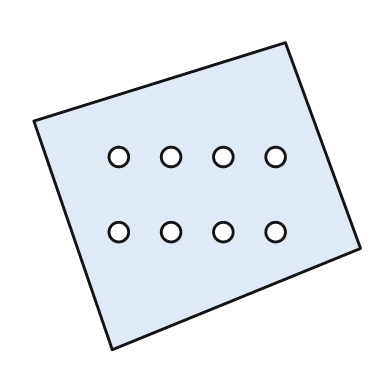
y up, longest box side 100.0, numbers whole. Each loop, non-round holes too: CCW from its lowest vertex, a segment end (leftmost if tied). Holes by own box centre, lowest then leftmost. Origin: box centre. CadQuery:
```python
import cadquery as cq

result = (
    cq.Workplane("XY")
    .moveTo(-26.0, -47.0)
    .lineTo(50.0, -16.0)
    .lineTo(27.0, 47.0)
    .lineTo(-50.0, 23.0)
    .close()
    .moveTo(-24.0, -11.0)
    .circle(3.0)
    .moveTo(-8.0, -11.0)
    .circle(3.0)
    .moveTo(8.0, -11.0)
    .circle(3.0)
    .moveTo(24.0, -11.0)
    .circle(3.0)
    .moveTo(-24.0, 12.0)
    .circle(3.0)
    .moveTo(-8.0, 12.0)
    .circle(3.0)
    .moveTo(8.0, 12.0)
    .circle(3.0)
    .moveTo(24.0, 12.0)
    .circle(3.0)
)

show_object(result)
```